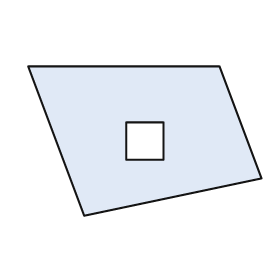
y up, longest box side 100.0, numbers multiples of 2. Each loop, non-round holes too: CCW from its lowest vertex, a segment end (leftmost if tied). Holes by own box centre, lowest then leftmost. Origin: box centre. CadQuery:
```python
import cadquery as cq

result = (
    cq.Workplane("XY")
    .moveTo(-26.0, -32.0)
    .lineTo(50.0, -16.0)
    .lineTo(32.0, 32.0)
    .lineTo(-50.0, 32.0)
    .close()
    .moveTo(-8.0, -8.0)
    .lineTo(8.0, -8.0)
    .lineTo(8.0, 8.0)
    .lineTo(-8.0, 8.0)
    .close()
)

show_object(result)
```